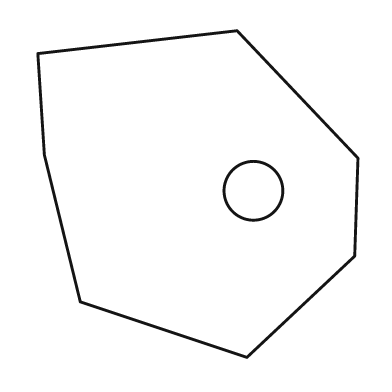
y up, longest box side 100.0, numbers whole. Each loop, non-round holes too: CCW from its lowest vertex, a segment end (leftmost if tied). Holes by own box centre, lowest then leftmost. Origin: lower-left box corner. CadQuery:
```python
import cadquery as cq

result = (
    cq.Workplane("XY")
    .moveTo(64.0, 0.0)
    .lineTo(97.0, 31.0)
    .lineTo(98.0, 61.0)
    .lineTo(61.0, 100.0)
    .lineTo(0.0, 93.0)
    .lineTo(2.0, 62.0)
    .lineTo(13.0, 17.0)
    .close()
    .moveTo(66.0, 51.0)
    .circle(9.0)
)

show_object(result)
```